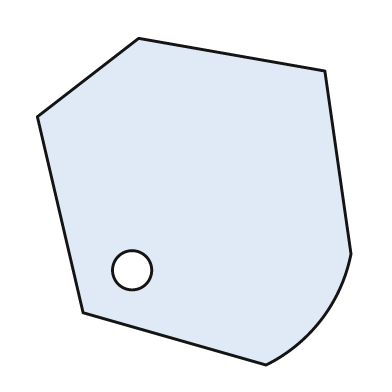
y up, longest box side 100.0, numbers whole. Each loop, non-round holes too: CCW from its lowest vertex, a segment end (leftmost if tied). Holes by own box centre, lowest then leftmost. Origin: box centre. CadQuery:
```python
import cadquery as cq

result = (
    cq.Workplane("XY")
    .moveTo(22.0, -50.0)
    .threePointArc((39.0, -36.0), (48.0, -16.0))
    .lineTo(40.0, 40.0)
    .lineTo(-17.0, 50.0)
    .lineTo(-48.0, 26.0)
    .lineTo(-34.0, -34.0)
    .close()
    .moveTo(-19.0, -21.0)
    .circle(6.0)
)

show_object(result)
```